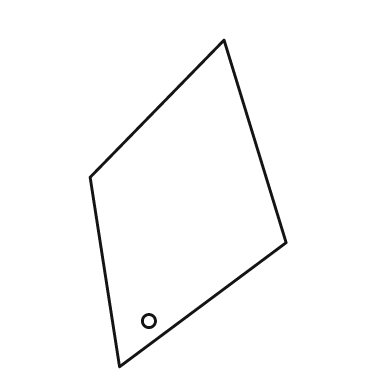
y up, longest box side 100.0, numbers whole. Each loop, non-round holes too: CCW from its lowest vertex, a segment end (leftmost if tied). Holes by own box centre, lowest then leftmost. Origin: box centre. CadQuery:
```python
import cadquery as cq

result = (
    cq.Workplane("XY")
    .moveTo(-21.0, -50.0)
    .lineTo(30.0, -12.0)
    .lineTo(11.0, 50.0)
    .lineTo(-30.0, 8.0)
    .close()
    .moveTo(-12.0, -36.0)
    .circle(2.0)
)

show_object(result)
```